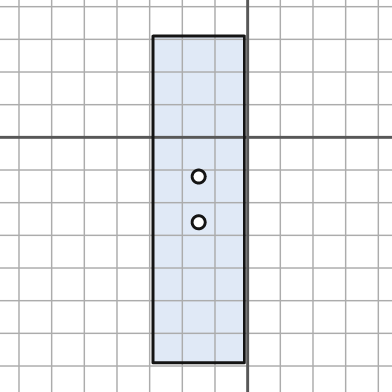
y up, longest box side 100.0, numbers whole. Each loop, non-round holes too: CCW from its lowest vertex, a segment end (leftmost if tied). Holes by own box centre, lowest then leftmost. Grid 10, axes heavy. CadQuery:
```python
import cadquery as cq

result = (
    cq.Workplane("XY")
    .moveTo(-29.0, -69.0)
    .lineTo(-1.0, -69.0)
    .lineTo(-1.0, 31.0)
    .lineTo(-29.0, 31.0)
    .close()
    .moveTo(-15.0, -26.0)
    .circle(2.0)
    .moveTo(-15.0, -12.0)
    .circle(2.0)
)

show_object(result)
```